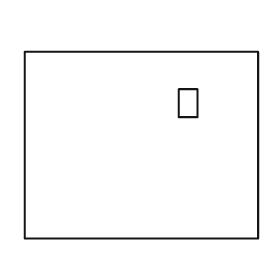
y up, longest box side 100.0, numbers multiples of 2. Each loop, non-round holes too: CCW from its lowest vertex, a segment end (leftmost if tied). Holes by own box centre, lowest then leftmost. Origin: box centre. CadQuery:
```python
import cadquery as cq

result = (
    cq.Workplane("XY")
    .moveTo(-50.0, -40.0)
    .lineTo(50.0, -40.0)
    .lineTo(50.0, 40.0)
    .lineTo(-50.0, 40.0)
    .close()
    .moveTo(16.0, 12.0)
    .lineTo(24.0, 12.0)
    .lineTo(24.0, 24.0)
    .lineTo(16.0, 24.0)
    .close()
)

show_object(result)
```